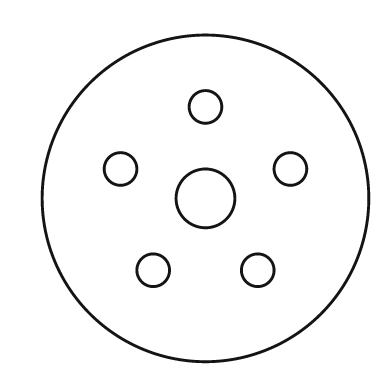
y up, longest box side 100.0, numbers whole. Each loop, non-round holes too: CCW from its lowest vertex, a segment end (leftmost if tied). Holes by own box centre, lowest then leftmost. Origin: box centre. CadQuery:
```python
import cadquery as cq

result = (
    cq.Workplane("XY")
    .moveTo(0.0, 0.0)
    .circle(50.0)
    .moveTo(-16.0, -22.0)
    .circle(5.0)
    .moveTo(16.0, -22.0)
    .circle(5.0)
    .moveTo(0.0, 0.0)
    .circle(9.0)
    .moveTo(-26.0, 9.0)
    .circle(5.0)
    .moveTo(26.0, 9.0)
    .circle(5.0)
    .moveTo(0.0, 28.0)
    .circle(5.0)
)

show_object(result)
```